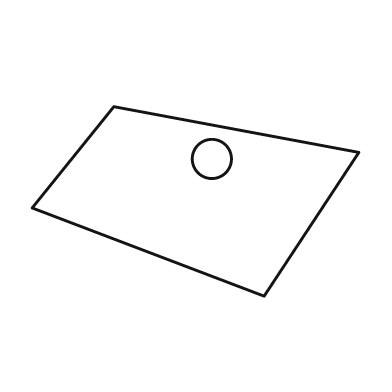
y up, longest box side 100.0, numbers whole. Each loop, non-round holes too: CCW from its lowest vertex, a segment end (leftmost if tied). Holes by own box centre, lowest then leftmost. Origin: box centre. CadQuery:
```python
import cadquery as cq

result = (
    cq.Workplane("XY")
    .moveTo(21.0, -29.0)
    .lineTo(50.0, 15.0)
    .lineTo(-25.0, 29.0)
    .lineTo(-50.0, -2.0)
    .close()
    .moveTo(5.0, 13.0)
    .circle(6.0)
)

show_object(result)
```